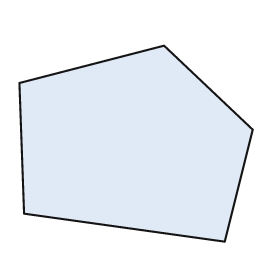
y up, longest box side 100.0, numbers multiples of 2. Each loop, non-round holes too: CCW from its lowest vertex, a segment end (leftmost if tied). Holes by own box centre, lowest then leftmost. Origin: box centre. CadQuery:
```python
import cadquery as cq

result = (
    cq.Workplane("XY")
    .moveTo(38.0, -42.0)
    .lineTo(50.0, 6.0)
    .lineTo(12.0, 42.0)
    .lineTo(-50.0, 26.0)
    .lineTo(-48.0, -30.0)
    .close()
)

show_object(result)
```